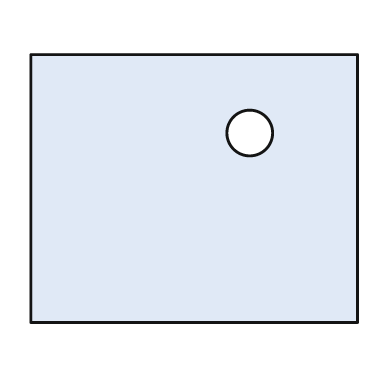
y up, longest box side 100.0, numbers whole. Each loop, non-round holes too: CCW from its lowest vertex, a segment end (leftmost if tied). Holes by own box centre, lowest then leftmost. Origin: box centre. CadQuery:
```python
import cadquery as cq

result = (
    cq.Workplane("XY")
    .moveTo(-50.0, -41.0)
    .lineTo(50.0, -41.0)
    .lineTo(50.0, 41.0)
    .lineTo(-50.0, 41.0)
    .close()
    .moveTo(17.0, 17.0)
    .circle(7.0)
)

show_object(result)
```